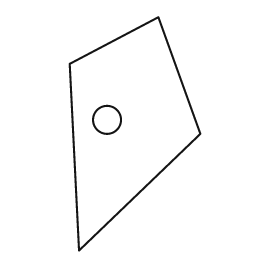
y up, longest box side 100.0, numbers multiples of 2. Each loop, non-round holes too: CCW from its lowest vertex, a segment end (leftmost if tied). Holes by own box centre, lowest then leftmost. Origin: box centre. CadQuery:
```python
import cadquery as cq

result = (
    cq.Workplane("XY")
    .moveTo(-24.0, -50.0)
    .lineTo(28.0, 0.0)
    .lineTo(10.0, 50.0)
    .lineTo(-28.0, 30.0)
    .close()
    .moveTo(-12.0, 6.0)
    .circle(6.0)
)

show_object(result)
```